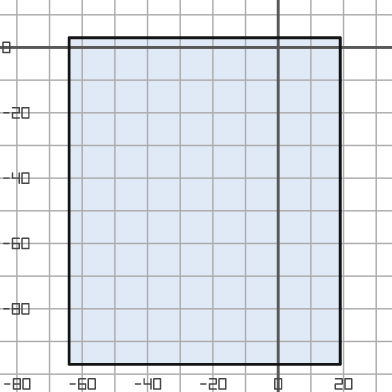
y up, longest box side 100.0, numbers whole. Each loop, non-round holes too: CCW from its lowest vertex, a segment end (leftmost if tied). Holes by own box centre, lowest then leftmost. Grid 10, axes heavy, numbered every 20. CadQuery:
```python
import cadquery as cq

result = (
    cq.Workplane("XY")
    .moveTo(-64.0, -97.0)
    .lineTo(19.0, -97.0)
    .lineTo(19.0, 3.0)
    .lineTo(-64.0, 3.0)
    .close()
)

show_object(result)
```